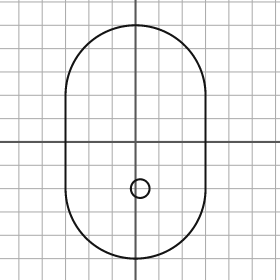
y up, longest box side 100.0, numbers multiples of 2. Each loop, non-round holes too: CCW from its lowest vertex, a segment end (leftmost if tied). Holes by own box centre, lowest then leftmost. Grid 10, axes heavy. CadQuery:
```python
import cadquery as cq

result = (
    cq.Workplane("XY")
    .moveTo(-30.0, -20.0)
    .threePointArc((0.0, -50.0), (30.0, -20.0))
    .lineTo(30.0, 20.0)
    .threePointArc((0.0, 50.0), (-30.0, 20.0))
    .close()
    .moveTo(2.0, -20.0)
    .circle(4.0)
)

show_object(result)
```